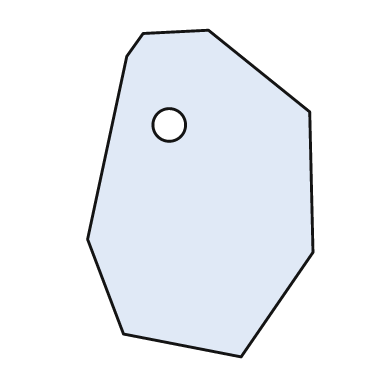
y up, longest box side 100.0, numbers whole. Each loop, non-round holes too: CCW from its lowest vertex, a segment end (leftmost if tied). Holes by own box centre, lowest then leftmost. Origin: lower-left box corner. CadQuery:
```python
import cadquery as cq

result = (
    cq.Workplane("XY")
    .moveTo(47.0, 0.0)
    .lineTo(69.0, 32.0)
    .lineTo(68.0, 75.0)
    .lineTo(37.0, 100.0)
    .lineTo(17.0, 99.0)
    .lineTo(12.0, 92.0)
    .lineTo(0.0, 36.0)
    .lineTo(11.0, 7.0)
    .close()
    .moveTo(25.0, 71.0)
    .circle(5.0)
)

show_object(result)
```